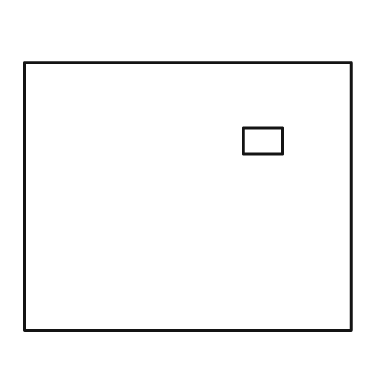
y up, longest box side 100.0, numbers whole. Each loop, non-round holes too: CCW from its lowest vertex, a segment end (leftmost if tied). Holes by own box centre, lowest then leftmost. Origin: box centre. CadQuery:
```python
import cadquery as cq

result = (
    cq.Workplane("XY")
    .moveTo(-50.0, -41.0)
    .lineTo(50.0, -41.0)
    .lineTo(50.0, 41.0)
    .lineTo(-50.0, 41.0)
    .close()
    .moveTo(17.0, 13.0)
    .lineTo(29.0, 13.0)
    .lineTo(29.0, 21.0)
    .lineTo(17.0, 21.0)
    .close()
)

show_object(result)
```